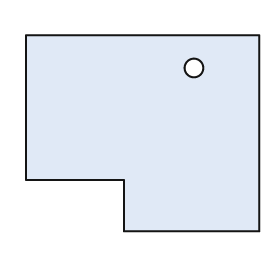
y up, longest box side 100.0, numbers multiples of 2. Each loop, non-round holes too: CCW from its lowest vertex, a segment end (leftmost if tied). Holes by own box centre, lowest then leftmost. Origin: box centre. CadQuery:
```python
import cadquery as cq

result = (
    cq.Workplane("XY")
    .moveTo(-8.0, -42.0)
    .lineTo(50.0, -42.0)
    .lineTo(50.0, 42.0)
    .lineTo(-50.0, 42.0)
    .lineTo(-50.0, -20.0)
    .lineTo(-8.0, -20.0)
    .close()
    .moveTo(22.0, 28.0)
    .circle(4.0)
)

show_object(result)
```